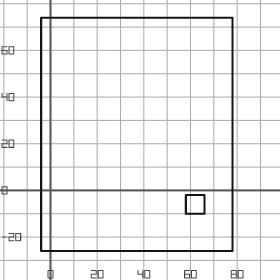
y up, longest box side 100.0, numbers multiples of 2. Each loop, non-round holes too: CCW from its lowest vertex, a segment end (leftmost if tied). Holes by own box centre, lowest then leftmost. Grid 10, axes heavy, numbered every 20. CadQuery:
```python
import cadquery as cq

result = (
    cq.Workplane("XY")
    .moveTo(-4.0, -26.0)
    .lineTo(78.0, -26.0)
    .lineTo(78.0, 74.0)
    .lineTo(-4.0, 74.0)
    .close()
    .moveTo(58.0, -10.0)
    .lineTo(66.0, -10.0)
    .lineTo(66.0, -2.0)
    .lineTo(58.0, -2.0)
    .close()
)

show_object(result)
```